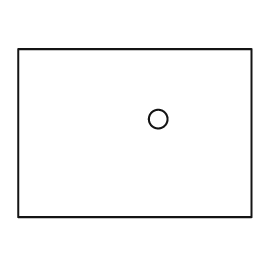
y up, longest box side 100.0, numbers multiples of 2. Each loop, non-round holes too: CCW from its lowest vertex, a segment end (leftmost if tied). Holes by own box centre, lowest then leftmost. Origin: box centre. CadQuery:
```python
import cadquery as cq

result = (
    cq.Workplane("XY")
    .moveTo(-50.0, -36.0)
    .lineTo(50.0, -36.0)
    .lineTo(50.0, 36.0)
    .lineTo(-50.0, 36.0)
    .close()
    .moveTo(10.0, 6.0)
    .circle(4.0)
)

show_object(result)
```